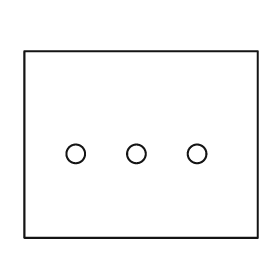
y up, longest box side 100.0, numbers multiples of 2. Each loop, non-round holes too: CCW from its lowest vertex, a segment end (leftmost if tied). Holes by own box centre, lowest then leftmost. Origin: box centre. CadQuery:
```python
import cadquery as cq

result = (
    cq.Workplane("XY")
    .moveTo(-50.0, -40.0)
    .lineTo(50.0, -40.0)
    .lineTo(50.0, 40.0)
    .lineTo(-50.0, 40.0)
    .close()
    .moveTo(-28.0, -4.0)
    .circle(4.0)
    .moveTo(-2.0, -4.0)
    .circle(4.0)
    .moveTo(24.0, -4.0)
    .circle(4.0)
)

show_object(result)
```